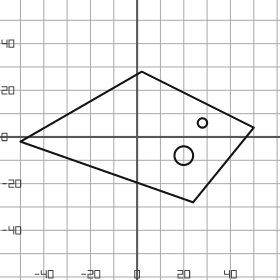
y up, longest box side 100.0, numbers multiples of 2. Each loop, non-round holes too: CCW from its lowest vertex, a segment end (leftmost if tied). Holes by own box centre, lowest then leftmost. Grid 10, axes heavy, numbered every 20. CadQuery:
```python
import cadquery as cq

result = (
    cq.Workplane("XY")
    .moveTo(24.0, -28.0)
    .lineTo(50.0, 4.0)
    .lineTo(2.0, 28.0)
    .lineTo(-50.0, -2.0)
    .close()
    .moveTo(20.0, -8.0)
    .circle(4.0)
    .moveTo(28.0, 6.0)
    .circle(2.0)
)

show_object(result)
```